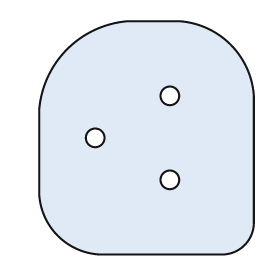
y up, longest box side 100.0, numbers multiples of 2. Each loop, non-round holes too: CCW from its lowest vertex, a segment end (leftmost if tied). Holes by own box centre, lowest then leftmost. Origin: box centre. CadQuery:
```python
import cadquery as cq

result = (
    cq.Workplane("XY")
    .moveTo(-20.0, -50.0)
    .lineTo(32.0, -50.0)
    .threePointArc((42.0, -46.0), (46.0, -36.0))
    .lineTo(46.0, 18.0)
    .threePointArc((36.0, 40.0), (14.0, 50.0))
    .lineTo(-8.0, 50.0)
    .threePointArc((-34.0, 38.0), (-46.0, 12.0))
    .lineTo(-46.0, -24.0)
    .threePointArc((-38.0, -42.0), (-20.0, -50.0))
    .close()
    .moveTo(10.0, -18.0)
    .circle(4.0)
    .moveTo(-22.0, 0.0)
    .circle(4.0)
    .moveTo(10.0, 18.0)
    .circle(4.0)
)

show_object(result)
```